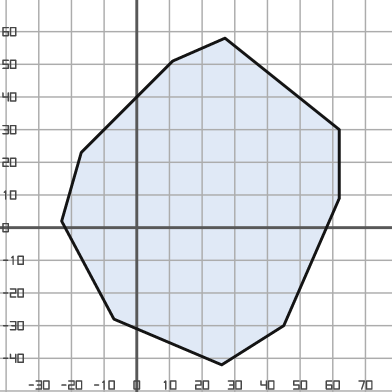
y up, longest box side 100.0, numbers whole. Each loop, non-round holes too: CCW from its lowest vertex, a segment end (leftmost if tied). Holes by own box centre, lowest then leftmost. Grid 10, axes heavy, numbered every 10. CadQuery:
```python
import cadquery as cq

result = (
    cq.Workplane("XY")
    .moveTo(26.0, -42.0)
    .lineTo(45.0, -30.0)
    .lineTo(62.0, 9.0)
    .lineTo(62.0, 30.0)
    .lineTo(27.0, 58.0)
    .lineTo(11.0, 51.0)
    .lineTo(-17.0, 23.0)
    .lineTo(-23.0, 2.0)
    .lineTo(-7.0, -28.0)
    .close()
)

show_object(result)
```